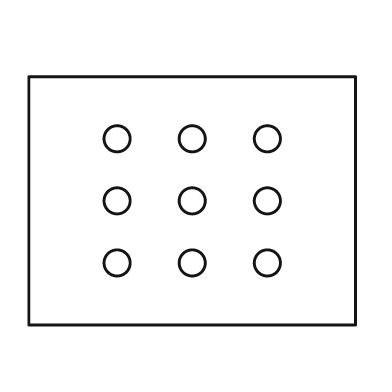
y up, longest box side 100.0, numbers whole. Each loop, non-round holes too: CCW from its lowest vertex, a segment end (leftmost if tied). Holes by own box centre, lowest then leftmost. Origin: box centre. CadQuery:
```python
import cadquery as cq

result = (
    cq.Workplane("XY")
    .moveTo(-50.0, -38.0)
    .lineTo(50.0, -38.0)
    .lineTo(50.0, 38.0)
    .lineTo(-50.0, 38.0)
    .close()
    .moveTo(-23.0, -19.0)
    .circle(4.0)
    .moveTo(0.0, -19.0)
    .circle(4.0)
    .moveTo(23.0, -19.0)
    .circle(4.0)
    .moveTo(-23.0, 0.0)
    .circle(4.0)
    .moveTo(0.0, 0.0)
    .circle(4.0)
    .moveTo(23.0, 0.0)
    .circle(4.0)
    .moveTo(-23.0, 19.0)
    .circle(4.0)
    .moveTo(0.0, 19.0)
    .circle(4.0)
    .moveTo(23.0, 19.0)
    .circle(4.0)
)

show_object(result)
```